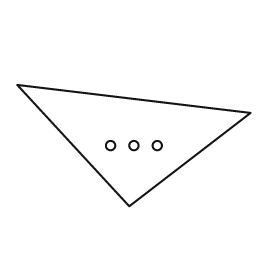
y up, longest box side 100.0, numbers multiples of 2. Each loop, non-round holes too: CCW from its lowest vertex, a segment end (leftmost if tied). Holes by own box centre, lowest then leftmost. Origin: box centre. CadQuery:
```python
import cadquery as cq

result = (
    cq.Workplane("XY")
    .moveTo(-2.0, -26.0)
    .lineTo(50.0, 14.0)
    .lineTo(-50.0, 26.0)
    .close()
    .moveTo(-10.0, 0.0)
    .circle(2.0)
    .moveTo(0.0, 0.0)
    .circle(2.0)
    .moveTo(10.0, 0.0)
    .circle(2.0)
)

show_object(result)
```